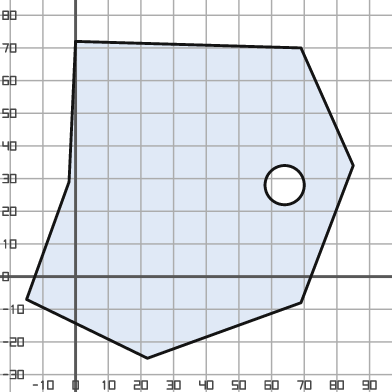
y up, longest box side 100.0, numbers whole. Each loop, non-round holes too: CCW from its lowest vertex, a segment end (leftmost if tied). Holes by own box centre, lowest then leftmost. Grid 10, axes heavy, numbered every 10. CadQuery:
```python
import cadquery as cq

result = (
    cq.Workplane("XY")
    .moveTo(22.0, -25.0)
    .lineTo(69.0, -8.0)
    .lineTo(85.0, 34.0)
    .lineTo(69.0, 70.0)
    .lineTo(0.0, 72.0)
    .lineTo(-2.0, 29.0)
    .lineTo(-15.0, -7.0)
    .close()
    .moveTo(64.0, 28.0)
    .circle(6.0)
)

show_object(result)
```